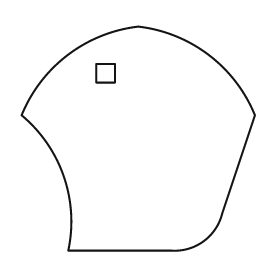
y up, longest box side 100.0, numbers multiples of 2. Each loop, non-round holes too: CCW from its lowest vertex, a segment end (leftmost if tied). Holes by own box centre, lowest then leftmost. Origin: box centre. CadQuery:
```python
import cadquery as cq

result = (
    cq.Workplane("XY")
    .moveTo(-30.0, -48.0)
    .lineTo(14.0, -48.0)
    .threePointArc((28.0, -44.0), (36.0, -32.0))
    .lineTo(50.0, 10.0)
    .threePointArc((30.0, 36.0), (0.0, 48.0))
    .threePointArc((-30.0, 36.0), (-50.0, 10.0))
    .threePointArc((-32.0, -16.0), (-30.0, -48.0))
    .close()
    .moveTo(-18.0, 24.0)
    .lineTo(-10.0, 24.0)
    .lineTo(-10.0, 32.0)
    .lineTo(-18.0, 32.0)
    .close()
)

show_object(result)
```